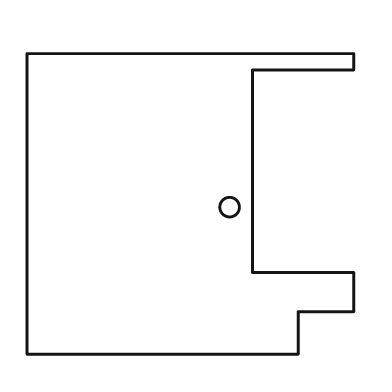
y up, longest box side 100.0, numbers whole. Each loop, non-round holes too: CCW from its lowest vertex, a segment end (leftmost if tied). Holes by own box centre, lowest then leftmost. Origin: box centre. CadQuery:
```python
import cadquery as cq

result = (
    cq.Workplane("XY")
    .moveTo(-50.0, -46.0)
    .lineTo(33.0, -46.0)
    .lineTo(33.0, -33.0)
    .lineTo(50.0, -33.0)
    .lineTo(50.0, -21.0)
    .lineTo(19.0, -21.0)
    .lineTo(19.0, 41.0)
    .lineTo(50.0, 41.0)
    .lineTo(50.0, 46.0)
    .lineTo(-50.0, 46.0)
    .close()
    .moveTo(12.0, -1.0)
    .circle(3.0)
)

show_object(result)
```